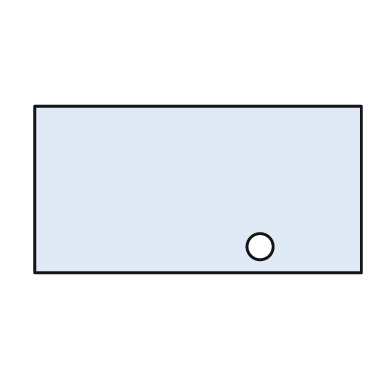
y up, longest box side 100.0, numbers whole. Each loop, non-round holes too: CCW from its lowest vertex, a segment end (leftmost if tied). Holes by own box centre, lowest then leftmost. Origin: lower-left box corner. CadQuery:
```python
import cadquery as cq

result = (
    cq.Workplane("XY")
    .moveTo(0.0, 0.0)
    .lineTo(100.0, 0.0)
    .lineTo(100.0, 51.0)
    .lineTo(0.0, 51.0)
    .close()
    .moveTo(69.0, 8.0)
    .circle(4.0)
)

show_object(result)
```